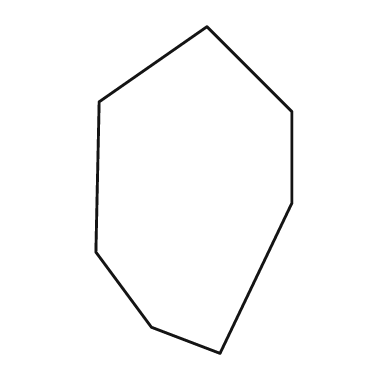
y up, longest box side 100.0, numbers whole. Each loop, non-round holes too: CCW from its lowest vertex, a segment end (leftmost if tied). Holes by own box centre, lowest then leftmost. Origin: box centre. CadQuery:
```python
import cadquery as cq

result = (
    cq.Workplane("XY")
    .moveTo(8.0, -50.0)
    .lineTo(30.0, -4.0)
    .lineTo(30.0, 24.0)
    .lineTo(4.0, 50.0)
    .lineTo(-29.0, 27.0)
    .lineTo(-30.0, -19.0)
    .lineTo(-13.0, -42.0)
    .close()
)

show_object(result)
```